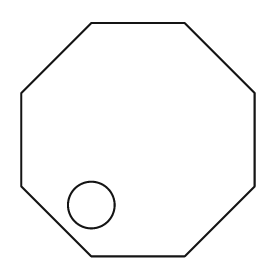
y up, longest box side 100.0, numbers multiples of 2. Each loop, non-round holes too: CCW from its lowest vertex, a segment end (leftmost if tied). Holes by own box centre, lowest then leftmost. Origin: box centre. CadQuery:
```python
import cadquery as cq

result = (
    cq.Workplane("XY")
    .moveTo(-20.0, -50.0)
    .lineTo(20.0, -50.0)
    .lineTo(50.0, -20.0)
    .lineTo(50.0, 20.0)
    .lineTo(20.0, 50.0)
    .lineTo(-20.0, 50.0)
    .lineTo(-50.0, 20.0)
    .lineTo(-50.0, -20.0)
    .close()
    .moveTo(-20.0, -28.0)
    .circle(10.0)
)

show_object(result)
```